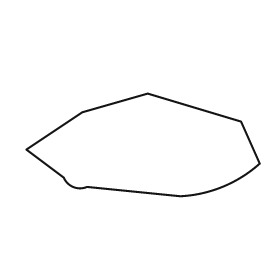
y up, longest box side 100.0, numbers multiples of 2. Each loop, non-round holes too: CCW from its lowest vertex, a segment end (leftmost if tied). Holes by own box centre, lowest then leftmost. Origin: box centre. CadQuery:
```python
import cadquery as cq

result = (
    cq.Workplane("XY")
    .moveTo(16.0, -22.0)
    .threePointArc((34.0, -18.0), (50.0, -8.0))
    .lineTo(42.0, 10.0)
    .lineTo(2.0, 22.0)
    .lineTo(-26.0, 14.0)
    .lineTo(-50.0, -2.0)
    .lineTo(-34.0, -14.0)
    .threePointArc((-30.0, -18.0), (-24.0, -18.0))
    .close()
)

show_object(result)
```